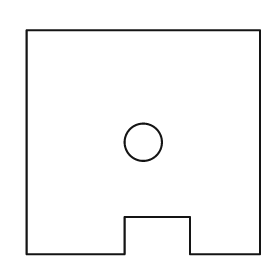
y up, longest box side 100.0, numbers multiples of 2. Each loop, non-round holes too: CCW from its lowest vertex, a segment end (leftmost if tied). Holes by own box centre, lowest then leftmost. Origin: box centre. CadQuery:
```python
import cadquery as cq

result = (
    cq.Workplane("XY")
    .moveTo(-50.0, -48.0)
    .lineTo(-8.0, -48.0)
    .lineTo(-8.0, -32.0)
    .lineTo(20.0, -32.0)
    .lineTo(20.0, -48.0)
    .lineTo(50.0, -48.0)
    .lineTo(50.0, 48.0)
    .lineTo(-50.0, 48.0)
    .close()
    .moveTo(0.0, 0.0)
    .circle(8.0)
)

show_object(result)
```